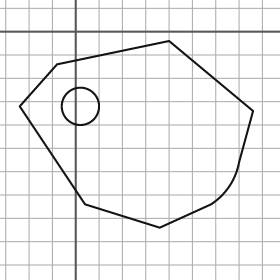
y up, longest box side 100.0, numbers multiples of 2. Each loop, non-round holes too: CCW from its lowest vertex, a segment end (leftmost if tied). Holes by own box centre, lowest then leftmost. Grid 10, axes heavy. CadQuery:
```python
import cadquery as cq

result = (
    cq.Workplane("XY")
    .moveTo(36.0, -84.0)
    .lineTo(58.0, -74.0)
    .threePointArc((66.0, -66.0), (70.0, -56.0))
    .lineTo(76.0, -34.0)
    .lineTo(40.0, -4.0)
    .lineTo(-8.0, -14.0)
    .lineTo(-24.0, -32.0)
    .lineTo(4.0, -74.0)
    .close()
    .moveTo(2.0, -32.0)
    .circle(8.0)
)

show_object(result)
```